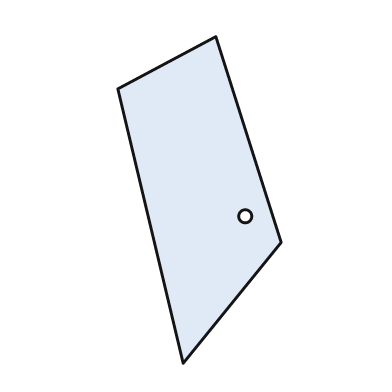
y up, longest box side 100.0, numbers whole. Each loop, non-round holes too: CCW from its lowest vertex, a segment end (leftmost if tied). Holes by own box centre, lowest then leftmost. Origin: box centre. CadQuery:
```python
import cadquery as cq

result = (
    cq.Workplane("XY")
    .moveTo(-5.0, -50.0)
    .lineTo(25.0, -13.0)
    .lineTo(5.0, 50.0)
    .lineTo(-25.0, 34.0)
    .close()
    .moveTo(14.0, -5.0)
    .circle(2.0)
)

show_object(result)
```